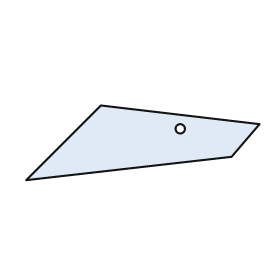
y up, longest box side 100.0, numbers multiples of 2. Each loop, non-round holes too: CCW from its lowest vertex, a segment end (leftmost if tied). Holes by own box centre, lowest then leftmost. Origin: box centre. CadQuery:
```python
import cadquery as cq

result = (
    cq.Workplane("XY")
    .moveTo(-50.0, -16.0)
    .lineTo(38.0, -6.0)
    .lineTo(50.0, 8.0)
    .lineTo(-18.0, 16.0)
    .close()
    .moveTo(16.0, 6.0)
    .circle(2.0)
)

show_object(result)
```